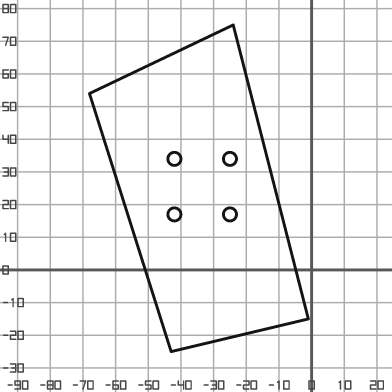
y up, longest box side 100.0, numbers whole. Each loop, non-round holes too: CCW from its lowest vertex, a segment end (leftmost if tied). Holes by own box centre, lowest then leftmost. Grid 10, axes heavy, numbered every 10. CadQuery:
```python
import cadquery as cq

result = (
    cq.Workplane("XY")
    .moveTo(-43.0, -25.0)
    .lineTo(-1.0, -15.0)
    .lineTo(-24.0, 75.0)
    .lineTo(-68.0, 54.0)
    .close()
    .moveTo(-42.0, 17.0)
    .circle(2.0)
    .moveTo(-25.0, 17.0)
    .circle(2.0)
    .moveTo(-42.0, 34.0)
    .circle(2.0)
    .moveTo(-25.0, 34.0)
    .circle(2.0)
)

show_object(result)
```